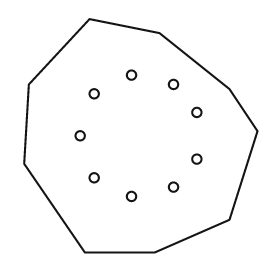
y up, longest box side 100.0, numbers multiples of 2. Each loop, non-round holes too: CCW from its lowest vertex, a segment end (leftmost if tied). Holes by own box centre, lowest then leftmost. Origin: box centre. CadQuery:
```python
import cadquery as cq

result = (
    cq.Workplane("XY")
    .moveTo(-24.0, -50.0)
    .lineTo(6.0, -50.0)
    .lineTo(38.0, -36.0)
    .lineTo(50.0, 2.0)
    .lineTo(38.0, 20.0)
    .lineTo(8.0, 44.0)
    .lineTo(-22.0, 50.0)
    .lineTo(-48.0, 22.0)
    .lineTo(-50.0, -12.0)
    .close()
    .moveTo(-4.0, -26.0)
    .circle(2.0)
    .moveTo(14.0, -22.0)
    .circle(2.0)
    .moveTo(-20.0, -18.0)
    .circle(2.0)
    .moveTo(24.0, -10.0)
    .circle(2.0)
    .moveTo(-26.0, 0.0)
    .circle(2.0)
    .moveTo(24.0, 10.0)
    .circle(2.0)
    .moveTo(-20.0, 18.0)
    .circle(2.0)
    .moveTo(14.0, 22.0)
    .circle(2.0)
    .moveTo(-4.0, 26.0)
    .circle(2.0)
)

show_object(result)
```